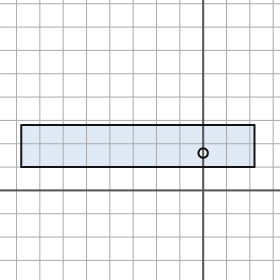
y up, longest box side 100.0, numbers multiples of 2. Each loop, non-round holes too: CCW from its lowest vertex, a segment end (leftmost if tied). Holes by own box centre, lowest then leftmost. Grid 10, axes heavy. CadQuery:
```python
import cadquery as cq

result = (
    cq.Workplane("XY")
    .moveTo(-78.0, 10.0)
    .lineTo(22.0, 10.0)
    .lineTo(22.0, 28.0)
    .lineTo(-78.0, 28.0)
    .close()
    .moveTo(0.0, 16.0)
    .circle(2.0)
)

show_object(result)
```